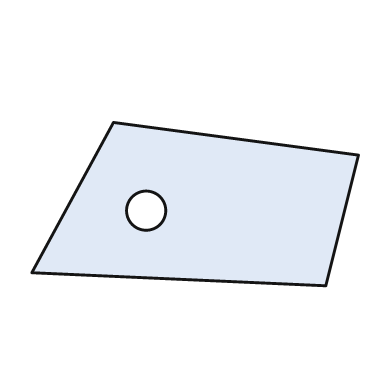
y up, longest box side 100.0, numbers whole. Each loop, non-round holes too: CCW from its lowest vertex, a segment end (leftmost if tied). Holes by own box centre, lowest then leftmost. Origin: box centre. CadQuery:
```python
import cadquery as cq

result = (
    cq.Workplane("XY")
    .moveTo(40.0, -25.0)
    .lineTo(50.0, 15.0)
    .lineTo(-25.0, 25.0)
    .lineTo(-50.0, -21.0)
    .close()
    .moveTo(-15.0, -2.0)
    .circle(6.0)
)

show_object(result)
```